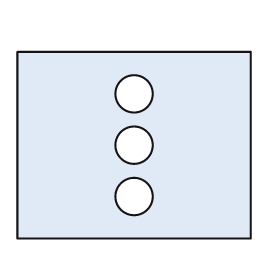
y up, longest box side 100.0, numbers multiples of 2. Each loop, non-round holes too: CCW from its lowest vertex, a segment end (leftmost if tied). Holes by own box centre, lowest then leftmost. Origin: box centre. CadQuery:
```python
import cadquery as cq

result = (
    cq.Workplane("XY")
    .moveTo(-50.0, -40.0)
    .lineTo(50.0, -40.0)
    .lineTo(50.0, 40.0)
    .lineTo(-50.0, 40.0)
    .close()
    .moveTo(0.0, -22.0)
    .circle(8.0)
    .moveTo(0.0, 0.0)
    .circle(8.0)
    .moveTo(0.0, 22.0)
    .circle(8.0)
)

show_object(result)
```